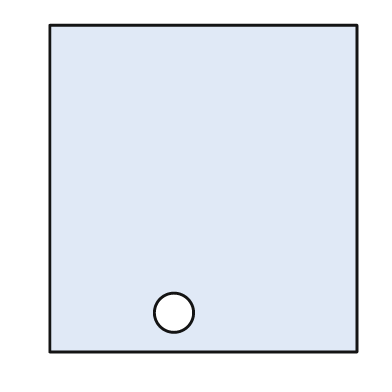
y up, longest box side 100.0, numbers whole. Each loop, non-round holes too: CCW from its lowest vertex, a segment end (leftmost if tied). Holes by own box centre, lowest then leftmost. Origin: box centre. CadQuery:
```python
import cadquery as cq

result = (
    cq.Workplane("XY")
    .moveTo(-47.0, -50.0)
    .lineTo(47.0, -50.0)
    .lineTo(47.0, 50.0)
    .lineTo(-47.0, 50.0)
    .close()
    .moveTo(-9.0, -38.0)
    .circle(6.0)
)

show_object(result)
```